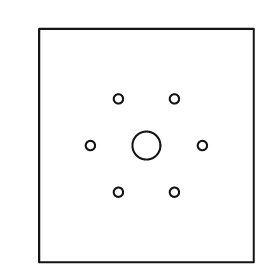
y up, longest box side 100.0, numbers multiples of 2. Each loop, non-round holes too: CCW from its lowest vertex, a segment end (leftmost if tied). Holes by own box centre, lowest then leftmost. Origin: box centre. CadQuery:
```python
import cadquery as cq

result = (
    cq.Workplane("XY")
    .moveTo(-46.0, -50.0)
    .lineTo(46.0, -50.0)
    .lineTo(46.0, 50.0)
    .lineTo(-46.0, 50.0)
    .close()
    .moveTo(-12.0, -20.0)
    .circle(2.0)
    .moveTo(12.0, -20.0)
    .circle(2.0)
    .moveTo(-24.0, 0.0)
    .circle(2.0)
    .moveTo(0.0, 0.0)
    .circle(6.0)
    .moveTo(24.0, 0.0)
    .circle(2.0)
    .moveTo(-12.0, 20.0)
    .circle(2.0)
    .moveTo(12.0, 20.0)
    .circle(2.0)
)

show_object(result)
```